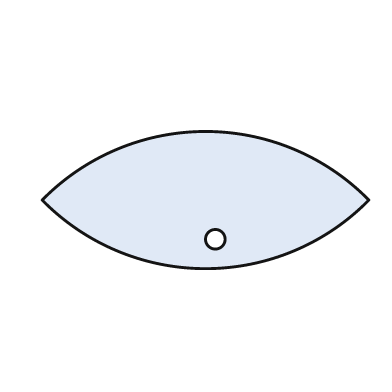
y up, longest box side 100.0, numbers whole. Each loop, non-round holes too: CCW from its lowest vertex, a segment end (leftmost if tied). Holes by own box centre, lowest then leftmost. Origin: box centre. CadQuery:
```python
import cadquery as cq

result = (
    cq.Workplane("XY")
    .moveTo(-50.0, 0.0)
    .threePointArc((0.0, -21.0), (50.0, 0.0))
    .threePointArc((0.0, 21.0), (-50.0, 0.0))
    .close()
    .moveTo(3.0, -12.0)
    .circle(3.0)
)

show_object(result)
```